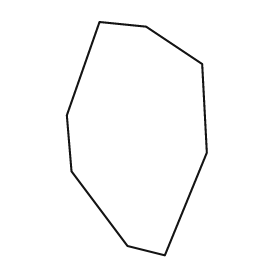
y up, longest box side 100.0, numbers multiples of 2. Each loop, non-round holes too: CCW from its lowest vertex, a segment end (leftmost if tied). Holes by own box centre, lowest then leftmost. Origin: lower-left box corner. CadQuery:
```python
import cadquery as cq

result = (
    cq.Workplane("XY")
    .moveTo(42.0, 0.0)
    .lineTo(60.0, 44.0)
    .lineTo(58.0, 82.0)
    .lineTo(34.0, 98.0)
    .lineTo(14.0, 100.0)
    .lineTo(0.0, 60.0)
    .lineTo(2.0, 36.0)
    .lineTo(26.0, 4.0)
    .close()
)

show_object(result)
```